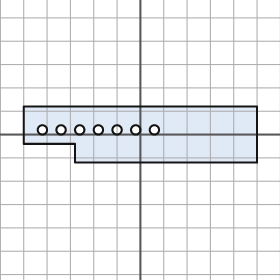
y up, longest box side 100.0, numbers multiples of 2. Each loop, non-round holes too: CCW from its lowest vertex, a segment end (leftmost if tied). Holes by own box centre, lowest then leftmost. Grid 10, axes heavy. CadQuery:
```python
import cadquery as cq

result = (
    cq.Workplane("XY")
    .moveTo(-28.0, -12.0)
    .lineTo(50.0, -12.0)
    .lineTo(50.0, 12.0)
    .lineTo(-50.0, 12.0)
    .lineTo(-50.0, -4.0)
    .lineTo(-28.0, -4.0)
    .close()
    .moveTo(-42.0, 2.0)
    .circle(2.0)
    .moveTo(-34.0, 2.0)
    .circle(2.0)
    .moveTo(-26.0, 2.0)
    .circle(2.0)
    .moveTo(-18.0, 2.0)
    .circle(2.0)
    .moveTo(-10.0, 2.0)
    .circle(2.0)
    .moveTo(-2.0, 2.0)
    .circle(2.0)
    .moveTo(6.0, 2.0)
    .circle(2.0)
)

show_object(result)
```